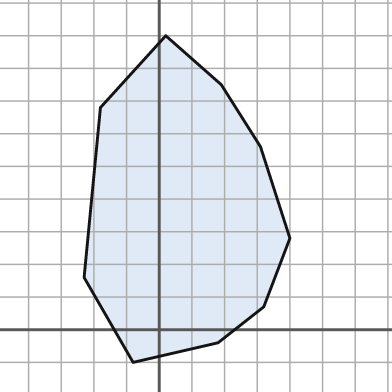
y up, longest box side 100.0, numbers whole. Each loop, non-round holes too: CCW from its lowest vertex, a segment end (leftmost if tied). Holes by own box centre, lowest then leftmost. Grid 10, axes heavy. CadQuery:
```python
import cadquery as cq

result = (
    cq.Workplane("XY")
    .moveTo(-8.0, -10.0)
    .lineTo(18.0, -4.0)
    .lineTo(32.0, 7.0)
    .lineTo(40.0, 28.0)
    .lineTo(31.0, 56.0)
    .lineTo(19.0, 75.0)
    .lineTo(2.0, 90.0)
    .lineTo(-18.0, 68.0)
    .lineTo(-23.0, 16.0)
    .close()
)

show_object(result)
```